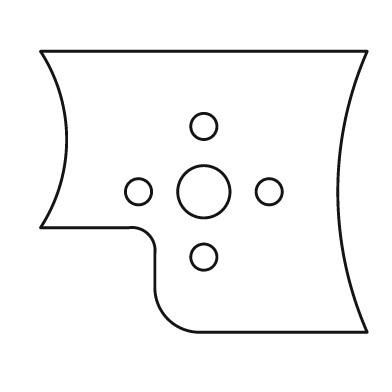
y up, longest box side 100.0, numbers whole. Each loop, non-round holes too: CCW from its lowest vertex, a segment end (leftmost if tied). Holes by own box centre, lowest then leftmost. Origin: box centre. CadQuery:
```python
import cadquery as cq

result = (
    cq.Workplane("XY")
    .moveTo(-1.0, -43.0)
    .lineTo(50.0, -43.0)
    .threePointArc((41.0, 0.0), (50.0, 43.0))
    .lineTo(-50.0, 43.0)
    .threePointArc((-42.0, 16.0), (-50.0, -11.0))
    .lineTo(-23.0, -11.0)
    .threePointArc((-17.0, -13.0), (-15.0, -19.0))
    .lineTo(-15.0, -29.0)
    .threePointArc((-11.0, -39.0), (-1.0, -43.0))
    .close()
    .moveTo(0.0, -20.0)
    .circle(4.0)
    .moveTo(-20.0, 0.0)
    .circle(4.0)
    .moveTo(0.0, 0.0)
    .circle(8.0)
    .moveTo(20.0, 0.0)
    .circle(4.0)
    .moveTo(0.0, 20.0)
    .circle(4.0)
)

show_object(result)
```